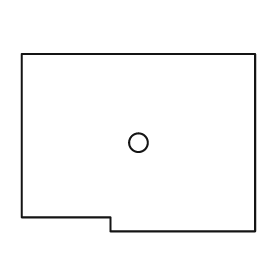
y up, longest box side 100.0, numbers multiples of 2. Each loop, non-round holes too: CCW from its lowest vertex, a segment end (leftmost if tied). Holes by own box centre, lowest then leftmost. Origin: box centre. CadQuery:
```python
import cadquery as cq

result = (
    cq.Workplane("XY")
    .moveTo(-12.0, -38.0)
    .lineTo(50.0, -38.0)
    .lineTo(50.0, 38.0)
    .lineTo(-50.0, 38.0)
    .lineTo(-50.0, -32.0)
    .lineTo(-12.0, -32.0)
    .close()
    .moveTo(0.0, 0.0)
    .circle(4.0)
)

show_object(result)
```